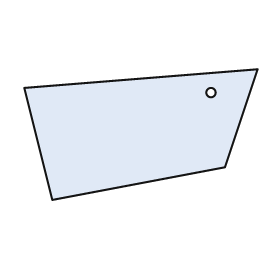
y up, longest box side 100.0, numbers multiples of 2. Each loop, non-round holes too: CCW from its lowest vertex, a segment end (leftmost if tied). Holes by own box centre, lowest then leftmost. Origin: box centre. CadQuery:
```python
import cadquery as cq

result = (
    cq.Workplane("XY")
    .moveTo(-38.0, -28.0)
    .lineTo(36.0, -14.0)
    .lineTo(50.0, 28.0)
    .lineTo(-50.0, 20.0)
    .close()
    .moveTo(30.0, 18.0)
    .circle(2.0)
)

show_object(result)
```